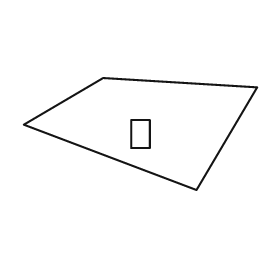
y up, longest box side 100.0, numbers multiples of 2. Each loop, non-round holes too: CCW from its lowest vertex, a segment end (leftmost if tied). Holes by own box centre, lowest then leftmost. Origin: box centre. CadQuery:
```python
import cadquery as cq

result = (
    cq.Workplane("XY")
    .moveTo(24.0, -24.0)
    .lineTo(50.0, 20.0)
    .lineTo(-16.0, 24.0)
    .lineTo(-50.0, 4.0)
    .close()
    .moveTo(-4.0, -6.0)
    .lineTo(4.0, -6.0)
    .lineTo(4.0, 6.0)
    .lineTo(-4.0, 6.0)
    .close()
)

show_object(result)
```